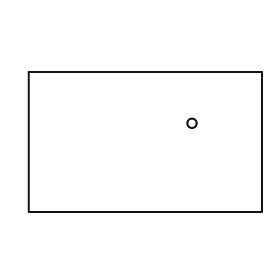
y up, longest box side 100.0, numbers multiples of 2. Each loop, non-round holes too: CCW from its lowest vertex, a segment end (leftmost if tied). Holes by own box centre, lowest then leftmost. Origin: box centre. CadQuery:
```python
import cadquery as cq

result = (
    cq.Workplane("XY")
    .moveTo(-50.0, -30.0)
    .lineTo(50.0, -30.0)
    .lineTo(50.0, 30.0)
    .lineTo(-50.0, 30.0)
    .close()
    .moveTo(20.0, 8.0)
    .circle(2.0)
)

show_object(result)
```